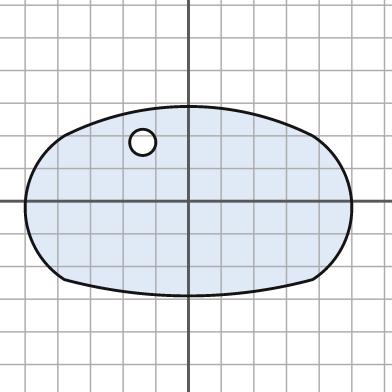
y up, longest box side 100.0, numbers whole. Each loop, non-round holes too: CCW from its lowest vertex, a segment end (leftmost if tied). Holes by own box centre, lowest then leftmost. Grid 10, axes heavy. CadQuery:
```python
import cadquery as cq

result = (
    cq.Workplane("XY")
    .moveTo(-38.0, -24.0)
    .threePointArc((0.0, -29.0), (38.0, -24.0))
    .threePointArc((50.0, -2.0), (38.0, 20.0))
    .threePointArc((0.0, 29.0), (-38.0, 20.0))
    .threePointArc((-50.0, -2.0), (-38.0, -24.0))
    .close()
    .moveTo(-14.0, 18.0)
    .circle(4.0)
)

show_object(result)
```